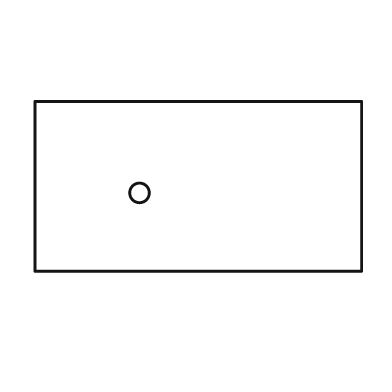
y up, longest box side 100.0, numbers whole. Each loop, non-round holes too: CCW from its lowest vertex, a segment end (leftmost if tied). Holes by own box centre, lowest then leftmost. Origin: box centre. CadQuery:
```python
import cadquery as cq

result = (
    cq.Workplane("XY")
    .moveTo(-50.0, -26.0)
    .lineTo(50.0, -26.0)
    .lineTo(50.0, 26.0)
    .lineTo(-50.0, 26.0)
    .close()
    .moveTo(-18.0, -2.0)
    .circle(3.0)
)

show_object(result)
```